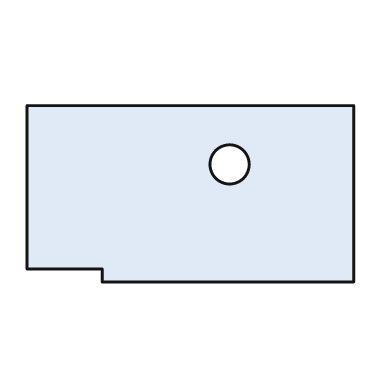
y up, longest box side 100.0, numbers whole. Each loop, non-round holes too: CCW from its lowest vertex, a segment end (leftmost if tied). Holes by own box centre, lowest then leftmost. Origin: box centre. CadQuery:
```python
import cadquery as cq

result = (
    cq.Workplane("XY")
    .moveTo(-27.0, -27.0)
    .lineTo(50.0, -27.0)
    .lineTo(50.0, 27.0)
    .lineTo(-50.0, 27.0)
    .lineTo(-50.0, -23.0)
    .lineTo(-27.0, -23.0)
    .close()
    .moveTo(12.0, 9.0)
    .circle(6.0)
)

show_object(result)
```